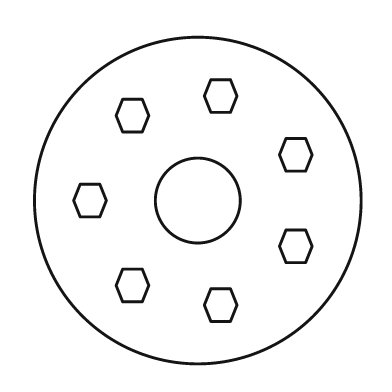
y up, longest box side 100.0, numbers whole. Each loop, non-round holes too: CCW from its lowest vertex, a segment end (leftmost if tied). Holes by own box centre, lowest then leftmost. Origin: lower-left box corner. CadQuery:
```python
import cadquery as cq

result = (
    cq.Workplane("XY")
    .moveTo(50.0, 50.0)
    .circle(50.0)
    .moveTo(54.0, 13.0)
    .lineTo(60.0, 13.0)
    .lineTo(62.0, 18.0)
    .lineTo(60.0, 23.0)
    .lineTo(54.0, 23.0)
    .lineTo(52.0, 18.0)
    .close()
    .moveTo(27.0, 19.0)
    .lineTo(33.0, 19.0)
    .lineTo(35.0, 24.0)
    .lineTo(33.0, 29.0)
    .lineTo(27.0, 29.0)
    .lineTo(25.0, 24.0)
    .close()
    .moveTo(77.0, 31.0)
    .lineTo(83.0, 31.0)
    .lineTo(85.0, 36.0)
    .lineTo(83.0, 41.0)
    .lineTo(77.0, 41.0)
    .lineTo(75.0, 36.0)
    .close()
    .moveTo(14.0, 45.0)
    .lineTo(20.0, 45.0)
    .lineTo(22.0, 50.0)
    .lineTo(20.0, 55.0)
    .lineTo(14.0, 55.0)
    .lineTo(12.0, 50.0)
    .close()
    .moveTo(50.0, 50.0)
    .circle(13.0)
    .moveTo(77.0, 59.0)
    .lineTo(83.0, 59.0)
    .lineTo(85.0, 64.0)
    .lineTo(83.0, 69.0)
    .lineTo(77.0, 69.0)
    .lineTo(75.0, 64.0)
    .close()
    .moveTo(27.0, 71.0)
    .lineTo(33.0, 71.0)
    .lineTo(35.0, 76.0)
    .lineTo(33.0, 81.0)
    .lineTo(27.0, 81.0)
    .lineTo(25.0, 76.0)
    .close()
    .moveTo(54.0, 77.0)
    .lineTo(60.0, 77.0)
    .lineTo(62.0, 82.0)
    .lineTo(60.0, 87.0)
    .lineTo(54.0, 87.0)
    .lineTo(52.0, 82.0)
    .close()
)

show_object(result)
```